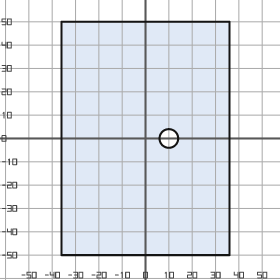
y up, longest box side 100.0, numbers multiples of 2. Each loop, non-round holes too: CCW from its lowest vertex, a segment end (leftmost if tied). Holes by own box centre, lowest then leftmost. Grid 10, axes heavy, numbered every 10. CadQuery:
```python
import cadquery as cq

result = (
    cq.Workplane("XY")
    .moveTo(-36.0, -50.0)
    .lineTo(36.0, -50.0)
    .lineTo(36.0, 50.0)
    .lineTo(-36.0, 50.0)
    .close()
    .moveTo(10.0, 0.0)
    .circle(4.0)
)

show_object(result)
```